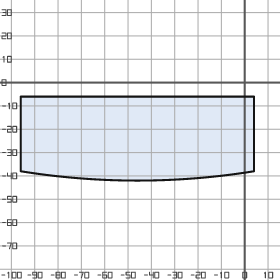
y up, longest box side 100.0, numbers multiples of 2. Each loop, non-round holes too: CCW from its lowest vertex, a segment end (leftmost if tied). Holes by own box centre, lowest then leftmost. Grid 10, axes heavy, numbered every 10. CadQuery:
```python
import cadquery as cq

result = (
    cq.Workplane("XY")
    .moveTo(-96.0, -38.0)
    .threePointArc((-46.0, -42.0), (4.0, -38.0))
    .lineTo(4.0, -6.0)
    .lineTo(-96.0, -6.0)
    .close()
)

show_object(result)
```